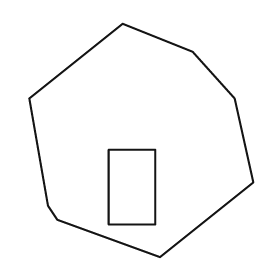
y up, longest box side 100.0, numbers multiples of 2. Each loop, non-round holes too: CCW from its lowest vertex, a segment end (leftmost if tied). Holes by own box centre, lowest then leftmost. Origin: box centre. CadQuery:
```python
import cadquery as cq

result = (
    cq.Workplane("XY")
    .moveTo(8.0, -50.0)
    .lineTo(48.0, -18.0)
    .lineTo(40.0, 18.0)
    .lineTo(22.0, 38.0)
    .lineTo(-8.0, 50.0)
    .lineTo(-48.0, 18.0)
    .lineTo(-40.0, -28.0)
    .lineTo(-36.0, -34.0)
    .close()
    .moveTo(-14.0, -36.0)
    .lineTo(6.0, -36.0)
    .lineTo(6.0, -4.0)
    .lineTo(-14.0, -4.0)
    .close()
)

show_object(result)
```